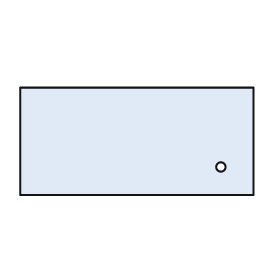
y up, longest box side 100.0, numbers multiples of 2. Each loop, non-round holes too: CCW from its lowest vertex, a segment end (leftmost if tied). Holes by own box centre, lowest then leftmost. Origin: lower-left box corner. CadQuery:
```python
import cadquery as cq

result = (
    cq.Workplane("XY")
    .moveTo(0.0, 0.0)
    .lineTo(100.0, 0.0)
    .lineTo(100.0, 46.0)
    .lineTo(0.0, 46.0)
    .close()
    .moveTo(86.0, 12.0)
    .circle(2.0)
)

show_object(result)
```